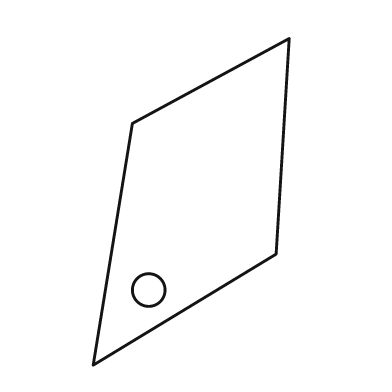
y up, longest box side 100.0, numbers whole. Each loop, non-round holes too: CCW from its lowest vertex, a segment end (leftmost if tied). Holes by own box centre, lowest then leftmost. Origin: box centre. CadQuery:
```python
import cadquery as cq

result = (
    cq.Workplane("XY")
    .moveTo(-30.0, -50.0)
    .lineTo(26.0, -16.0)
    .lineTo(30.0, 50.0)
    .lineTo(-18.0, 24.0)
    .close()
    .moveTo(-13.0, -27.0)
    .circle(5.0)
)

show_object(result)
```